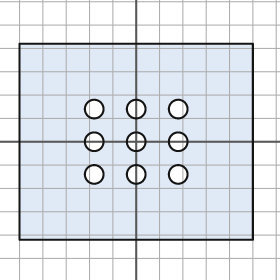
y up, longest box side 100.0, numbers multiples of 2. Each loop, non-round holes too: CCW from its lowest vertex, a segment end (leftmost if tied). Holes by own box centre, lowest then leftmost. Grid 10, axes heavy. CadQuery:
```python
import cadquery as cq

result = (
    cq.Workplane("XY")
    .moveTo(-50.0, -42.0)
    .lineTo(50.0, -42.0)
    .lineTo(50.0, 42.0)
    .lineTo(-50.0, 42.0)
    .close()
    .moveTo(-18.0, -14.0)
    .circle(4.0)
    .moveTo(0.0, -14.0)
    .circle(4.0)
    .moveTo(18.0, -14.0)
    .circle(4.0)
    .moveTo(-18.0, 0.0)
    .circle(4.0)
    .moveTo(0.0, 0.0)
    .circle(4.0)
    .moveTo(18.0, 0.0)
    .circle(4.0)
    .moveTo(-18.0, 14.0)
    .circle(4.0)
    .moveTo(0.0, 14.0)
    .circle(4.0)
    .moveTo(18.0, 14.0)
    .circle(4.0)
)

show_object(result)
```